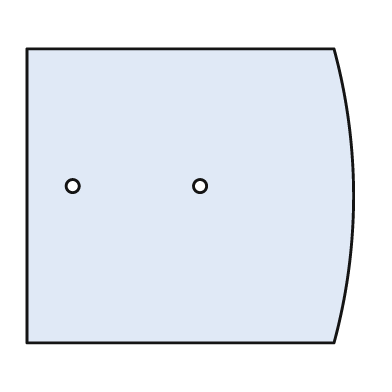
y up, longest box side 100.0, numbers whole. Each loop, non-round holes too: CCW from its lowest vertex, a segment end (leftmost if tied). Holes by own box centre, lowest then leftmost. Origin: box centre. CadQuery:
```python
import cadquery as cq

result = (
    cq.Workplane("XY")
    .moveTo(-50.0, -45.0)
    .lineTo(44.0, -45.0)
    .threePointArc((50.0, 0.0), (44.0, 45.0))
    .lineTo(-50.0, 45.0)
    .close()
    .moveTo(-36.0, 3.0)
    .circle(2.0)
    .moveTo(3.0, 3.0)
    .circle(2.0)
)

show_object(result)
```